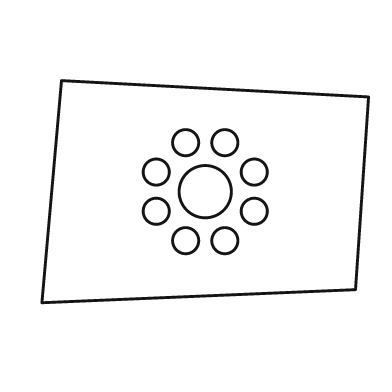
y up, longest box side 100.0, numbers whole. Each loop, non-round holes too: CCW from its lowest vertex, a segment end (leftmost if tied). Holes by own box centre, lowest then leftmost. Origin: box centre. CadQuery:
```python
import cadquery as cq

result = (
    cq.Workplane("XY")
    .moveTo(-50.0, -34.0)
    .lineTo(46.0, -30.0)
    .lineTo(50.0, 29.0)
    .lineTo(-44.0, 34.0)
    .close()
    .moveTo(-6.0, -15.0)
    .circle(4.0)
    .moveTo(6.0, -15.0)
    .circle(4.0)
    .moveTo(-15.0, -6.0)
    .circle(4.0)
    .moveTo(15.0, -6.0)
    .circle(4.0)
    .moveTo(0.0, 0.0)
    .circle(8.0)
    .moveTo(-15.0, 6.0)
    .circle(4.0)
    .moveTo(15.0, 6.0)
    .circle(4.0)
    .moveTo(-6.0, 15.0)
    .circle(4.0)
    .moveTo(6.0, 15.0)
    .circle(4.0)
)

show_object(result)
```